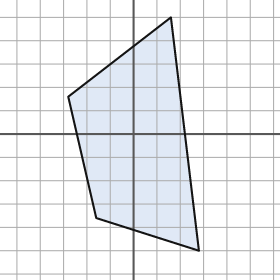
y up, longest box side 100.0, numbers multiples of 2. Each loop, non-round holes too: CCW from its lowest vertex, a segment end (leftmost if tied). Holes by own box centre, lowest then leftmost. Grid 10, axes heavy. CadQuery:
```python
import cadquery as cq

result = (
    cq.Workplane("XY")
    .moveTo(28.0, -50.0)
    .lineTo(16.0, 50.0)
    .lineTo(-28.0, 16.0)
    .lineTo(-16.0, -36.0)
    .close()
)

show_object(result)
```